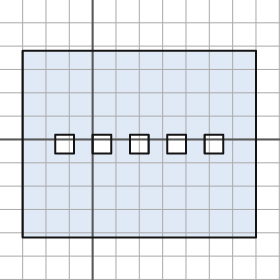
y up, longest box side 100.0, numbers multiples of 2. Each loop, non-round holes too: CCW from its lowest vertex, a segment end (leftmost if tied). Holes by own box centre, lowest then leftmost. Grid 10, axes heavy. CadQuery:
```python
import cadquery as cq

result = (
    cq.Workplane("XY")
    .moveTo(-30.0, -42.0)
    .lineTo(70.0, -42.0)
    .lineTo(70.0, 38.0)
    .lineTo(-30.0, 38.0)
    .close()
    .moveTo(-16.0, -6.0)
    .lineTo(-8.0, -6.0)
    .lineTo(-8.0, 2.0)
    .lineTo(-16.0, 2.0)
    .close()
    .moveTo(0.0, -6.0)
    .lineTo(8.0, -6.0)
    .lineTo(8.0, 2.0)
    .lineTo(0.0, 2.0)
    .close()
    .moveTo(16.0, -6.0)
    .lineTo(24.0, -6.0)
    .lineTo(24.0, 2.0)
    .lineTo(16.0, 2.0)
    .close()
    .moveTo(32.0, -6.0)
    .lineTo(40.0, -6.0)
    .lineTo(40.0, 2.0)
    .lineTo(32.0, 2.0)
    .close()
    .moveTo(48.0, -6.0)
    .lineTo(56.0, -6.0)
    .lineTo(56.0, 2.0)
    .lineTo(48.0, 2.0)
    .close()
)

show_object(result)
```